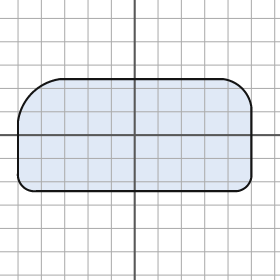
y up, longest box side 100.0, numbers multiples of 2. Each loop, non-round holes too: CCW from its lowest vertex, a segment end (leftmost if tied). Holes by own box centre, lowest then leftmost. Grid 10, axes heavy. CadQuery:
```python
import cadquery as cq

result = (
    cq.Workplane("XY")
    .moveTo(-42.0, -24.0)
    .lineTo(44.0, -24.0)
    .threePointArc((48.0, -22.0), (50.0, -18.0))
    .lineTo(50.0, 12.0)
    .threePointArc((46.0, 20.0), (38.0, 24.0))
    .lineTo(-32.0, 24.0)
    .threePointArc((-44.0, 18.0), (-50.0, 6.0))
    .lineTo(-50.0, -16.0)
    .threePointArc((-48.0, -22.0), (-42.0, -24.0))
    .close()
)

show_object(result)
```